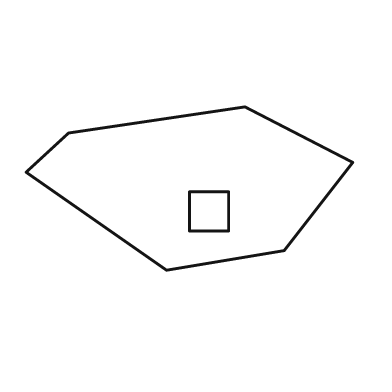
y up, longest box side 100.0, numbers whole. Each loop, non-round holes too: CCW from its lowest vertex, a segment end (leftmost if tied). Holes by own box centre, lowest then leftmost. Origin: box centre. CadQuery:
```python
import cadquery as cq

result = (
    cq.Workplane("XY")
    .moveTo(-7.0, -25.0)
    .lineTo(29.0, -19.0)
    .lineTo(50.0, 8.0)
    .lineTo(17.0, 25.0)
    .lineTo(-37.0, 17.0)
    .lineTo(-50.0, 5.0)
    .close()
    .moveTo(0.0, -13.0)
    .lineTo(12.0, -13.0)
    .lineTo(12.0, -1.0)
    .lineTo(0.0, -1.0)
    .close()
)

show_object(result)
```